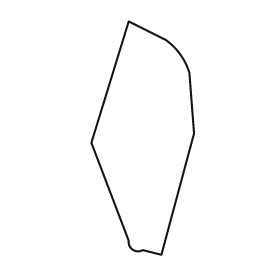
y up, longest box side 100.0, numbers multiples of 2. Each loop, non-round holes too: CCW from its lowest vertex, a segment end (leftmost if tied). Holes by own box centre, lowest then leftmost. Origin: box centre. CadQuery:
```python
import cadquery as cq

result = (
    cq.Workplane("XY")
    .moveTo(8.0, -50.0)
    .lineTo(22.0, 2.0)
    .lineTo(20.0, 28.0)
    .threePointArc((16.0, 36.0), (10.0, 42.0))
    .lineTo(-6.0, 50.0)
    .lineTo(-22.0, -2.0)
    .lineTo(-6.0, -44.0)
    .threePointArc((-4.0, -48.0), (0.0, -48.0))
    .close()
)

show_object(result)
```